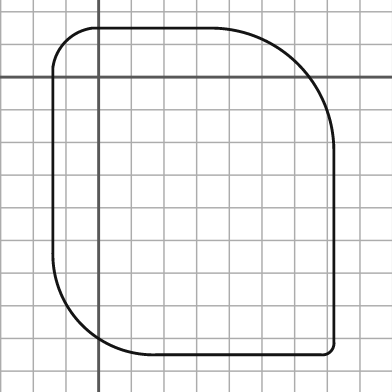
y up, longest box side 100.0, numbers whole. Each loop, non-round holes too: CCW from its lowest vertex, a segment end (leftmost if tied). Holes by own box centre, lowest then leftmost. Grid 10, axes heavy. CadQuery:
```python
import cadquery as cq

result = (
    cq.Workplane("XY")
    .moveTo(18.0, -85.0)
    .lineTo(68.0, -85.0)
    .threePointArc((71.0, -84.0), (72.0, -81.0))
    .lineTo(72.0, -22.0)
    .threePointArc((61.0, 4.0), (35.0, 15.0))
    .lineTo(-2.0, 15.0)
    .threePointArc((-10.0, 11.0), (-14.0, 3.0))
    .lineTo(-14.0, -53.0)
    .threePointArc((-5.0, -76.0), (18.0, -85.0))
    .close()
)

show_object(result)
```